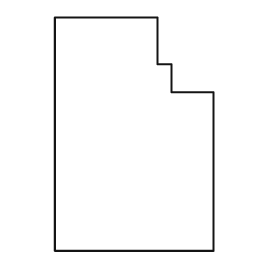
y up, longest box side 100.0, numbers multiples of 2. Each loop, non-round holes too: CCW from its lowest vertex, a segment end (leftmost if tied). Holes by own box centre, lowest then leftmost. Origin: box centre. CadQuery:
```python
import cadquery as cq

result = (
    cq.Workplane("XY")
    .moveTo(-34.0, -50.0)
    .lineTo(34.0, -50.0)
    .lineTo(34.0, 18.0)
    .lineTo(16.0, 18.0)
    .lineTo(16.0, 30.0)
    .lineTo(10.0, 30.0)
    .lineTo(10.0, 50.0)
    .lineTo(-34.0, 50.0)
    .close()
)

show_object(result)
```